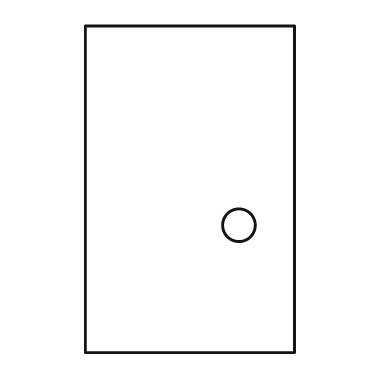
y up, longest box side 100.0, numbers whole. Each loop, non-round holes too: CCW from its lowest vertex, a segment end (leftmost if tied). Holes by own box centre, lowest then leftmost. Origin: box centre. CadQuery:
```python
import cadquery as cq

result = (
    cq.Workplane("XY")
    .moveTo(-32.0, -50.0)
    .lineTo(32.0, -50.0)
    .lineTo(32.0, 50.0)
    .lineTo(-32.0, 50.0)
    .close()
    .moveTo(15.0, -11.0)
    .circle(5.0)
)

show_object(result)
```